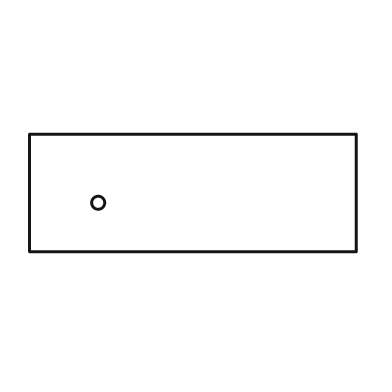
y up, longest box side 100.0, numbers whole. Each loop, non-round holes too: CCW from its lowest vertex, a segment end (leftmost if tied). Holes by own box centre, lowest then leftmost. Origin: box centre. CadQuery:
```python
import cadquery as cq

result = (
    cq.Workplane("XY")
    .moveTo(-50.0, -18.0)
    .lineTo(50.0, -18.0)
    .lineTo(50.0, 18.0)
    .lineTo(-50.0, 18.0)
    .close()
    .moveTo(-29.0, -3.0)
    .circle(2.0)
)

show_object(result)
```